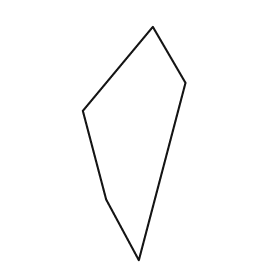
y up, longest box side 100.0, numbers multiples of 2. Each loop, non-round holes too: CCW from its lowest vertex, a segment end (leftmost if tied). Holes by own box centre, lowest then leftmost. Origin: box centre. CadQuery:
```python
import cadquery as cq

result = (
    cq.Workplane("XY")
    .moveTo(2.0, -50.0)
    .lineTo(22.0, 26.0)
    .lineTo(8.0, 50.0)
    .lineTo(-22.0, 14.0)
    .lineTo(-12.0, -24.0)
    .close()
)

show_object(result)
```